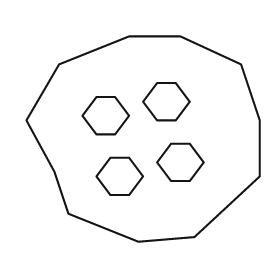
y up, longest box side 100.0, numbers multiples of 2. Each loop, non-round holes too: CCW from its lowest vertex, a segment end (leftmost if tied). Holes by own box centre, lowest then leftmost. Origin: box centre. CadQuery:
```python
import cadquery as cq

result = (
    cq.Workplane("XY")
    .moveTo(-2.0, -44.0)
    .lineTo(22.0, -42.0)
    .lineTo(50.0, -16.0)
    .lineTo(50.0, 8.0)
    .lineTo(42.0, 32.0)
    .lineTo(16.0, 44.0)
    .lineTo(-6.0, 44.0)
    .lineTo(-36.0, 32.0)
    .lineTo(-50.0, 8.0)
    .lineTo(-38.0, -14.0)
    .lineTo(-32.0, -32.0)
    .close()
    .moveTo(-14.0, -24.0)
    .lineTo(-6.0, -24.0)
    .lineTo(0.0, -16.0)
    .lineTo(-6.0, -8.0)
    .lineTo(-14.0, -8.0)
    .lineTo(-20.0, -16.0)
    .close()
    .moveTo(12.0, -18.0)
    .lineTo(20.0, -18.0)
    .lineTo(26.0, -10.0)
    .lineTo(20.0, -2.0)
    .lineTo(12.0, -2.0)
    .lineTo(6.0, -10.0)
    .close()
    .moveTo(-20.0, 2.0)
    .lineTo(-12.0, 2.0)
    .lineTo(-6.0, 10.0)
    .lineTo(-12.0, 18.0)
    .lineTo(-20.0, 18.0)
    .lineTo(-26.0, 10.0)
    .close()
    .moveTo(6.0, 8.0)
    .lineTo(14.0, 8.0)
    .lineTo(20.0, 16.0)
    .lineTo(14.0, 24.0)
    .lineTo(6.0, 24.0)
    .lineTo(0.0, 16.0)
    .close()
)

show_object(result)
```